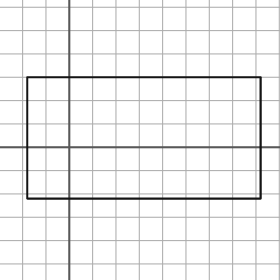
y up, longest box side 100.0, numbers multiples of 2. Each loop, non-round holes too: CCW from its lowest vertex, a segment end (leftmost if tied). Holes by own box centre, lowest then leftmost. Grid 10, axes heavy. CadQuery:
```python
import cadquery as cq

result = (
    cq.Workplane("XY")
    .moveTo(-18.0, -22.0)
    .lineTo(82.0, -22.0)
    .lineTo(82.0, 30.0)
    .lineTo(-18.0, 30.0)
    .close()
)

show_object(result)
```